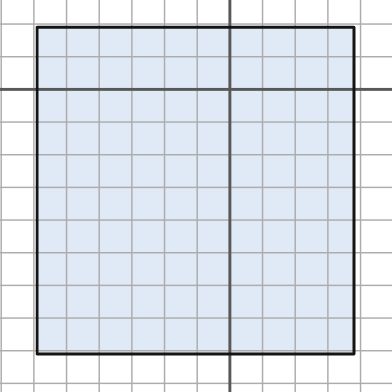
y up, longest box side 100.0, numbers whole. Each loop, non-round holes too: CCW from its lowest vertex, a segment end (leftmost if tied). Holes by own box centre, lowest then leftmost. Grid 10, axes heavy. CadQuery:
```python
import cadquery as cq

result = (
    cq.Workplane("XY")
    .moveTo(-59.0, -81.0)
    .lineTo(38.0, -81.0)
    .lineTo(38.0, 19.0)
    .lineTo(-59.0, 19.0)
    .close()
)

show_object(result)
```